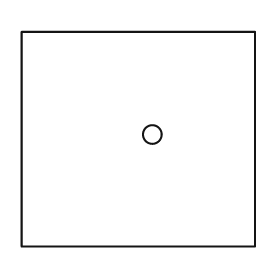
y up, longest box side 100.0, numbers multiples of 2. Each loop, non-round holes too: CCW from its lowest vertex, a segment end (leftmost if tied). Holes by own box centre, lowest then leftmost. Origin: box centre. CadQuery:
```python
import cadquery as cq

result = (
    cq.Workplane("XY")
    .moveTo(-50.0, -46.0)
    .lineTo(50.0, -46.0)
    .lineTo(50.0, 46.0)
    .lineTo(-50.0, 46.0)
    .close()
    .moveTo(6.0, 2.0)
    .circle(4.0)
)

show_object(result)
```